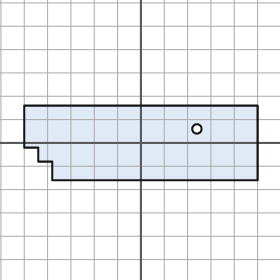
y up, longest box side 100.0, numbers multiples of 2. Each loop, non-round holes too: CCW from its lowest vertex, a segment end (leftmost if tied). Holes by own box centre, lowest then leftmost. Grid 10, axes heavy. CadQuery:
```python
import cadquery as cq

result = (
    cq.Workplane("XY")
    .moveTo(-38.0, -16.0)
    .lineTo(50.0, -16.0)
    .lineTo(50.0, 16.0)
    .lineTo(-50.0, 16.0)
    .lineTo(-50.0, -2.0)
    .lineTo(-44.0, -2.0)
    .lineTo(-44.0, -8.0)
    .lineTo(-38.0, -8.0)
    .close()
    .moveTo(24.0, 6.0)
    .circle(2.0)
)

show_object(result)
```